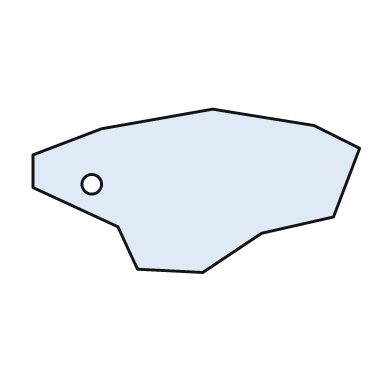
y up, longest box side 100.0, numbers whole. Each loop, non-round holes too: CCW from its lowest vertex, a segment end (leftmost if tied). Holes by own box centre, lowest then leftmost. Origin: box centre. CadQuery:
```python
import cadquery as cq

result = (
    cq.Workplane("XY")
    .moveTo(2.0, -25.0)
    .lineTo(20.0, -13.0)
    .lineTo(42.0, -8.0)
    .lineTo(50.0, 13.0)
    .lineTo(36.0, 20.0)
    .lineTo(5.0, 25.0)
    .lineTo(-29.0, 19.0)
    .lineTo(-50.0, 11.0)
    .lineTo(-50.0, 1.0)
    .lineTo(-24.0, -11.0)
    .lineTo(-18.0, -24.0)
    .close()
    .moveTo(-32.0, 2.0)
    .circle(3.0)
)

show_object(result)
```